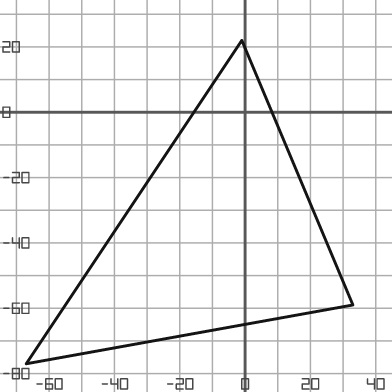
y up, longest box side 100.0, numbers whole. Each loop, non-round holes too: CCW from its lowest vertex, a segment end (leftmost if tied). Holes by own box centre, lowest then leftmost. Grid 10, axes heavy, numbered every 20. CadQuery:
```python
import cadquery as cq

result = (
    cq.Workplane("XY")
    .moveTo(-67.0, -77.0)
    .lineTo(33.0, -59.0)
    .lineTo(-1.0, 22.0)
    .close()
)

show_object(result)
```